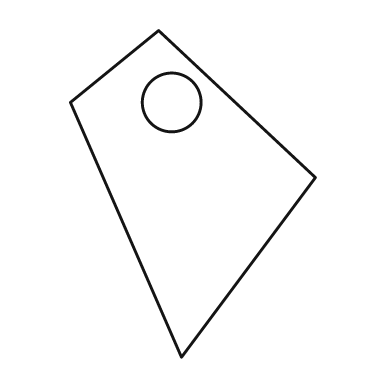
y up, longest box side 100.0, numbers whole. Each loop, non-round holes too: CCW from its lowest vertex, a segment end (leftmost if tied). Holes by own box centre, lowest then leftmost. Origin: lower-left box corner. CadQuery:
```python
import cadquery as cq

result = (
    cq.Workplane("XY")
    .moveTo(34.0, 0.0)
    .lineTo(75.0, 55.0)
    .lineTo(27.0, 100.0)
    .lineTo(0.0, 78.0)
    .close()
    .moveTo(31.0, 78.0)
    .circle(9.0)
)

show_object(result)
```